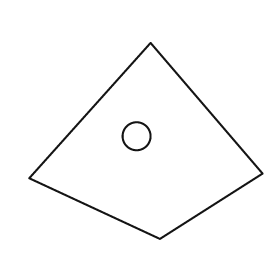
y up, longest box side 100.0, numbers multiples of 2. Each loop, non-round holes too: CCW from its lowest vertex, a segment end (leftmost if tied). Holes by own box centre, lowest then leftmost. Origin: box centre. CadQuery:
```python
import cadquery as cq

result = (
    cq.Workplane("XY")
    .moveTo(6.0, -42.0)
    .lineTo(50.0, -14.0)
    .lineTo(2.0, 42.0)
    .lineTo(-50.0, -16.0)
    .close()
    .moveTo(-4.0, 2.0)
    .circle(6.0)
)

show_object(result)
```